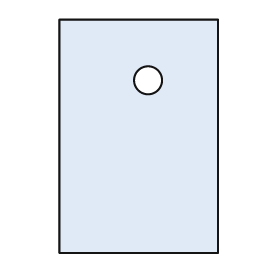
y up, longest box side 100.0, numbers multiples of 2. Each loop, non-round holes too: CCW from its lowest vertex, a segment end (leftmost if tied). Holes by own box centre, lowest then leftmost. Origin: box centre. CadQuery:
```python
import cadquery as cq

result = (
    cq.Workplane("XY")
    .moveTo(-34.0, -50.0)
    .lineTo(34.0, -50.0)
    .lineTo(34.0, 50.0)
    .lineTo(-34.0, 50.0)
    .close()
    .moveTo(4.0, 24.0)
    .circle(6.0)
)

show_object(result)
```